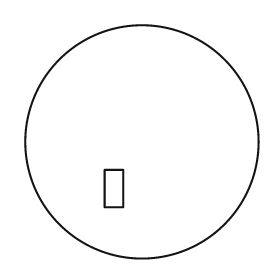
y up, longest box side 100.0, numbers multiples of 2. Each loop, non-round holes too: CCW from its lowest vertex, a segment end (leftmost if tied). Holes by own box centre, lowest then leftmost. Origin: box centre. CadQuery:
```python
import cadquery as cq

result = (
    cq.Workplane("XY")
    .moveTo(0.0, 0.0)
    .circle(50.0)
    .moveTo(-16.0, -28.0)
    .lineTo(-8.0, -28.0)
    .lineTo(-8.0, -12.0)
    .lineTo(-16.0, -12.0)
    .close()
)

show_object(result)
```